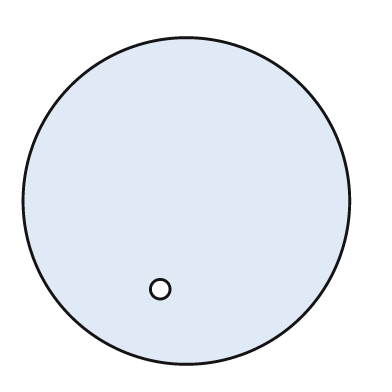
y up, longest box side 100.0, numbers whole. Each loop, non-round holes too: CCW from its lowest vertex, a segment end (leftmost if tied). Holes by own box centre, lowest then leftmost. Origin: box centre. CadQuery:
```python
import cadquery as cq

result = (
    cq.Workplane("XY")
    .moveTo(0.0, 0.0)
    .circle(50.0)
    .moveTo(-8.0, -27.0)
    .circle(3.0)
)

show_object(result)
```